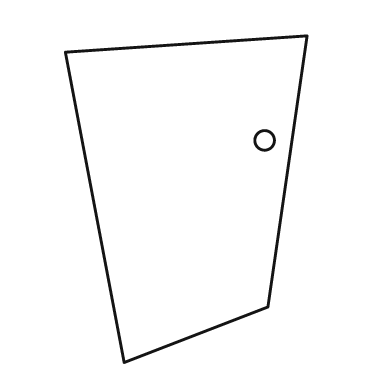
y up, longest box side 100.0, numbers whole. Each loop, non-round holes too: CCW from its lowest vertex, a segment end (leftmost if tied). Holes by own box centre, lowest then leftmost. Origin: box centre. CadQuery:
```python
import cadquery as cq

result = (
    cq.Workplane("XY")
    .moveTo(-19.0, -50.0)
    .lineTo(25.0, -33.0)
    .lineTo(37.0, 50.0)
    .lineTo(-37.0, 45.0)
    .close()
    .moveTo(24.0, 18.0)
    .circle(3.0)
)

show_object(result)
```